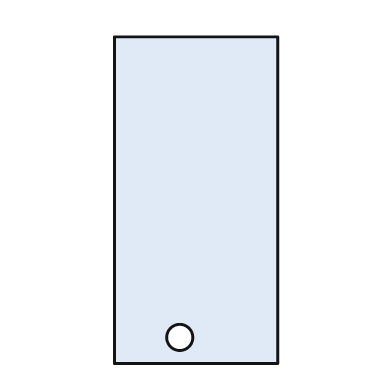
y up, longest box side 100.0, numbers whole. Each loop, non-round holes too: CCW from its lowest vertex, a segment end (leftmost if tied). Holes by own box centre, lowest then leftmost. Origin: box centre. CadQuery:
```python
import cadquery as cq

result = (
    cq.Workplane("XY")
    .moveTo(-25.0, -50.0)
    .lineTo(25.0, -50.0)
    .lineTo(25.0, 50.0)
    .lineTo(-25.0, 50.0)
    .close()
    .moveTo(-5.0, -42.0)
    .circle(4.0)
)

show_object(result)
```